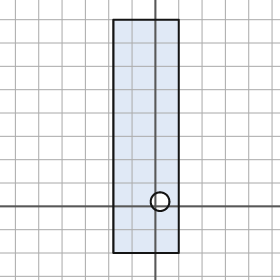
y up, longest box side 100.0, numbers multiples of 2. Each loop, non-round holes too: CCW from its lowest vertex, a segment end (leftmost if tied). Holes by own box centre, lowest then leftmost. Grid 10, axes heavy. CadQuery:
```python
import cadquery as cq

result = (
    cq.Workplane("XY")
    .moveTo(-18.0, -20.0)
    .lineTo(10.0, -20.0)
    .lineTo(10.0, 80.0)
    .lineTo(-18.0, 80.0)
    .close()
    .moveTo(2.0, 2.0)
    .circle(4.0)
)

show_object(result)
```